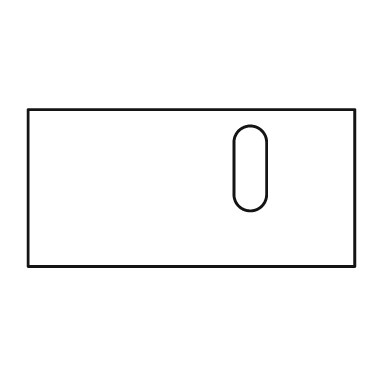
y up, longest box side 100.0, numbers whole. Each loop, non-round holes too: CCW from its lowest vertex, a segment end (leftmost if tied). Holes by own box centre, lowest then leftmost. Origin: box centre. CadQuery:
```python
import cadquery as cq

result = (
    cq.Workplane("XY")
    .moveTo(-50.0, -24.0)
    .lineTo(50.0, -24.0)
    .lineTo(50.0, 24.0)
    .lineTo(-50.0, 24.0)
    .close()
    .moveTo(13.0, -2.0)
    .threePointArc((18.0, -7.0), (23.0, -2.0))
    .lineTo(23.0, 14.0)
    .threePointArc((18.0, 19.0), (13.0, 14.0))
    .close()
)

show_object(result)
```